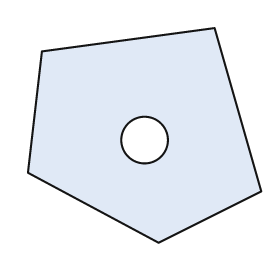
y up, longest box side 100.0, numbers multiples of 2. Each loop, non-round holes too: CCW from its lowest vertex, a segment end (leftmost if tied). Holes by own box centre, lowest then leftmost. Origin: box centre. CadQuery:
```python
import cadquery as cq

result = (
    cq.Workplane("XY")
    .moveTo(6.0, -46.0)
    .lineTo(50.0, -24.0)
    .lineTo(30.0, 46.0)
    .lineTo(-44.0, 36.0)
    .lineTo(-50.0, -16.0)
    .close()
    .moveTo(0.0, -2.0)
    .circle(10.0)
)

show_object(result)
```